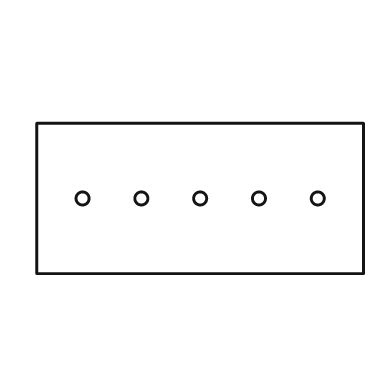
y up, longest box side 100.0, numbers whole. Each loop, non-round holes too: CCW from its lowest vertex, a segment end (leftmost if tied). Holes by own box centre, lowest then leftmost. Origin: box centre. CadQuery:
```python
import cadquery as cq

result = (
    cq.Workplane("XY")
    .moveTo(-50.0, -23.0)
    .lineTo(50.0, -23.0)
    .lineTo(50.0, 23.0)
    .lineTo(-50.0, 23.0)
    .close()
    .moveTo(-36.0, 0.0)
    .circle(2.0)
    .moveTo(-18.0, 0.0)
    .circle(2.0)
    .moveTo(0.0, 0.0)
    .circle(2.0)
    .moveTo(18.0, 0.0)
    .circle(2.0)
    .moveTo(36.0, 0.0)
    .circle(2.0)
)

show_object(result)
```